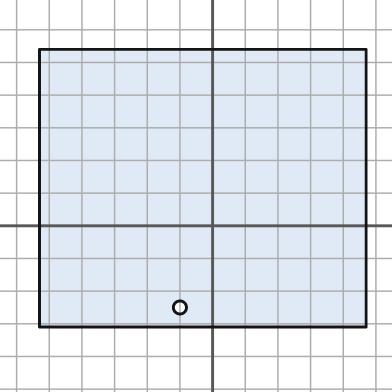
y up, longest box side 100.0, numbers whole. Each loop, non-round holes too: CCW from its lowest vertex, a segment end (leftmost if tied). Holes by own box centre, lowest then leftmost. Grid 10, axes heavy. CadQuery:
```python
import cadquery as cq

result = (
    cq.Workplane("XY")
    .moveTo(-53.0, -31.0)
    .lineTo(47.0, -31.0)
    .lineTo(47.0, 54.0)
    .lineTo(-53.0, 54.0)
    .close()
    .moveTo(-10.0, -25.0)
    .circle(2.0)
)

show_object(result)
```